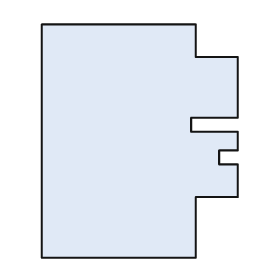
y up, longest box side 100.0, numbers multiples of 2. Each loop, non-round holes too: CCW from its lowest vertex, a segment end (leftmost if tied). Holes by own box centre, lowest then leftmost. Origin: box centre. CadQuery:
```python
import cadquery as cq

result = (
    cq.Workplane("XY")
    .moveTo(-42.0, -50.0)
    .lineTo(24.0, -50.0)
    .lineTo(24.0, -24.0)
    .lineTo(42.0, -24.0)
    .lineTo(42.0, -10.0)
    .lineTo(34.0, -10.0)
    .lineTo(34.0, -4.0)
    .lineTo(42.0, -4.0)
    .lineTo(42.0, 4.0)
    .lineTo(22.0, 4.0)
    .lineTo(22.0, 10.0)
    .lineTo(42.0, 10.0)
    .lineTo(42.0, 36.0)
    .lineTo(24.0, 36.0)
    .lineTo(24.0, 50.0)
    .lineTo(-42.0, 50.0)
    .close()
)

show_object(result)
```